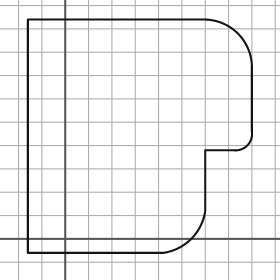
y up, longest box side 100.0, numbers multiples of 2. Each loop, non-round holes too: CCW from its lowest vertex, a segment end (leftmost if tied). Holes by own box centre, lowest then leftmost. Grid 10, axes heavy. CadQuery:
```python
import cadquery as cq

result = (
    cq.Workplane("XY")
    .moveTo(-16.0, -6.0)
    .lineTo(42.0, -6.0)
    .threePointArc((54.0, 0.0), (60.0, 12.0))
    .lineTo(60.0, 38.0)
    .lineTo(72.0, 38.0)
    .threePointArc((78.0, 40.0), (80.0, 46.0))
    .lineTo(80.0, 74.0)
    .threePointArc((74.0, 88.0), (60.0, 94.0))
    .lineTo(-16.0, 94.0)
    .close()
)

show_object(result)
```